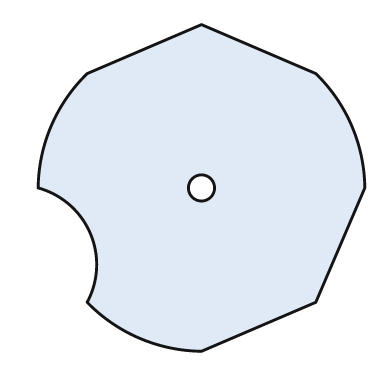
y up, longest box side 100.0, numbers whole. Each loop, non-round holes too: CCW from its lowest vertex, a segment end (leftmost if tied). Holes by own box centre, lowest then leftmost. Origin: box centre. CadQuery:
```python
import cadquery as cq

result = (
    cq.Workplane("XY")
    .moveTo(0.0, -50.0)
    .lineTo(35.0, -35.0)
    .lineTo(50.0, 0.0)
    .threePointArc((46.0, 19.0), (35.0, 35.0))
    .lineTo(0.0, 50.0)
    .lineTo(-35.0, 35.0)
    .threePointArc((-46.0, 19.0), (-50.0, 0.0))
    .threePointArc((-34.0, -14.0), (-35.0, -35.0))
    .threePointArc((-19.0, -46.0), (0.0, -50.0))
    .close()
    .moveTo(0.0, 0.0)
    .circle(4.0)
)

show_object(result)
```